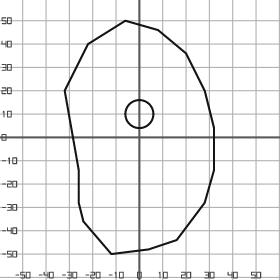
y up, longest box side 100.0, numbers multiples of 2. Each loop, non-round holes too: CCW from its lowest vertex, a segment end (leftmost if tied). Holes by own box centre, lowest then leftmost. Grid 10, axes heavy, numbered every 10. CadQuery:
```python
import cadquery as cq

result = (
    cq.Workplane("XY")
    .moveTo(-12.0, -50.0)
    .lineTo(4.0, -48.0)
    .lineTo(16.0, -44.0)
    .lineTo(28.0, -28.0)
    .lineTo(32.0, -14.0)
    .lineTo(32.0, 4.0)
    .lineTo(28.0, 20.0)
    .lineTo(20.0, 36.0)
    .lineTo(8.0, 46.0)
    .lineTo(-6.0, 50.0)
    .lineTo(-22.0, 40.0)
    .lineTo(-32.0, 20.0)
    .lineTo(-26.0, -14.0)
    .lineTo(-26.0, -28.0)
    .lineTo(-24.0, -36.0)
    .close()
    .moveTo(0.0, 10.0)
    .circle(6.0)
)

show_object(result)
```